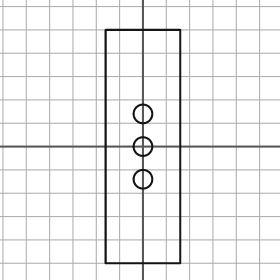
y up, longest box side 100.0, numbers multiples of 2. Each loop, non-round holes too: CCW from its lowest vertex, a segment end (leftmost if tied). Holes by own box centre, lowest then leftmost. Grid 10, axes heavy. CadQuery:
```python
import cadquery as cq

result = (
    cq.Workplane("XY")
    .moveTo(-16.0, -50.0)
    .lineTo(16.0, -50.0)
    .lineTo(16.0, 50.0)
    .lineTo(-16.0, 50.0)
    .close()
    .moveTo(0.0, -14.0)
    .circle(4.0)
    .moveTo(0.0, 0.0)
    .circle(4.0)
    .moveTo(0.0, 14.0)
    .circle(4.0)
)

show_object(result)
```